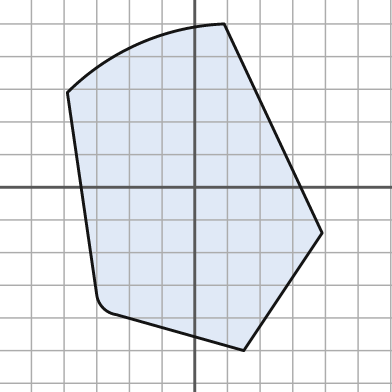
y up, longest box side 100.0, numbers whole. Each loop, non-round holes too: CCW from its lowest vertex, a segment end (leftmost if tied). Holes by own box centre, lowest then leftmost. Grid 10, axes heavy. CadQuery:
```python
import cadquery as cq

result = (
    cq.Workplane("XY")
    .moveTo(15.0, -50.0)
    .lineTo(39.0, -14.0)
    .lineTo(9.0, 50.0)
    .threePointArc((-17.0, 44.0), (-39.0, 29.0))
    .lineTo(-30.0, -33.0)
    .threePointArc((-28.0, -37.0), (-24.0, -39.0))
    .close()
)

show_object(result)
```